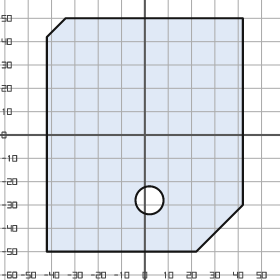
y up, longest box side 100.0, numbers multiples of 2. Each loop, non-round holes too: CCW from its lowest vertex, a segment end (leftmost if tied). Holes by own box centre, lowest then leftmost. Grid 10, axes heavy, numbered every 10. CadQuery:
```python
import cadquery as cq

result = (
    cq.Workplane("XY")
    .moveTo(-42.0, -50.0)
    .lineTo(22.0, -50.0)
    .lineTo(42.0, -30.0)
    .lineTo(42.0, 50.0)
    .lineTo(-34.0, 50.0)
    .lineTo(-42.0, 42.0)
    .close()
    .moveTo(2.0, -28.0)
    .circle(6.0)
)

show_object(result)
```